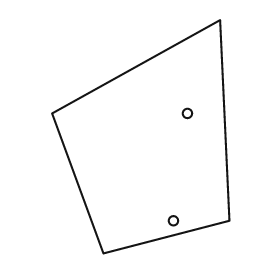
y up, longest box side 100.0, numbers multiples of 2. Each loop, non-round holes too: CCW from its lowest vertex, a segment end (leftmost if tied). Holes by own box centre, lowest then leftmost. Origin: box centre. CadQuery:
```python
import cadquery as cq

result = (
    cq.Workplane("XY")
    .moveTo(-16.0, -50.0)
    .lineTo(38.0, -36.0)
    .lineTo(34.0, 50.0)
    .lineTo(-38.0, 10.0)
    .close()
    .moveTo(14.0, -36.0)
    .circle(2.0)
    .moveTo(20.0, 10.0)
    .circle(2.0)
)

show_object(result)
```